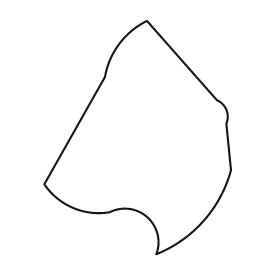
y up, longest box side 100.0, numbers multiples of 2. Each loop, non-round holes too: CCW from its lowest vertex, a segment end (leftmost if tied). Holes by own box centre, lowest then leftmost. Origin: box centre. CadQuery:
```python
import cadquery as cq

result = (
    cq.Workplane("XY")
    .moveTo(8.0, -50.0)
    .threePointArc((28.0, -36.0), (40.0, -14.0))
    .lineTo(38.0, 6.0)
    .threePointArc((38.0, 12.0), (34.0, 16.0))
    .lineTo(4.0, 50.0)
    .threePointArc((-8.0, 40.0), (-14.0, 26.0))
    .lineTo(-40.0, -20.0)
    .threePointArc((-28.0, -30.0), (-12.0, -32.0))
    .threePointArc((4.0, -34.0), (8.0, -50.0))
    .close()
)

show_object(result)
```